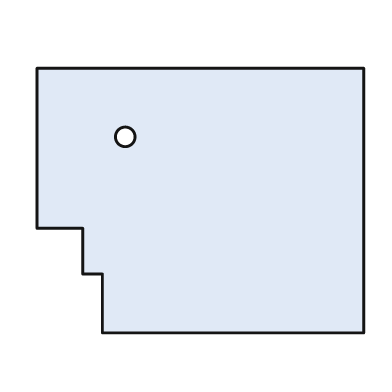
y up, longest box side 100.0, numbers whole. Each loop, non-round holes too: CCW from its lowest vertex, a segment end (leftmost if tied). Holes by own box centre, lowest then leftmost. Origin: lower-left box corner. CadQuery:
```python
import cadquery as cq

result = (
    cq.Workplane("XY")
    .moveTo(20.0, 0.0)
    .lineTo(100.0, 0.0)
    .lineTo(100.0, 81.0)
    .lineTo(0.0, 81.0)
    .lineTo(0.0, 32.0)
    .lineTo(14.0, 32.0)
    .lineTo(14.0, 18.0)
    .lineTo(20.0, 18.0)
    .close()
    .moveTo(27.0, 60.0)
    .circle(3.0)
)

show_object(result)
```